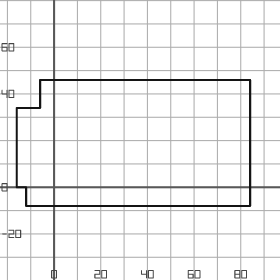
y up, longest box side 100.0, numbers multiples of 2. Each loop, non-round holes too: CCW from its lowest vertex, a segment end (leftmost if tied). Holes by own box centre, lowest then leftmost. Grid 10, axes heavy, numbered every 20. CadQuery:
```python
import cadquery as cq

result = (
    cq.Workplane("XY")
    .moveTo(-12.0, -8.0)
    .lineTo(84.0, -8.0)
    .lineTo(84.0, 46.0)
    .lineTo(-6.0, 46.0)
    .lineTo(-6.0, 34.0)
    .lineTo(-16.0, 34.0)
    .lineTo(-16.0, 0.0)
    .lineTo(-12.0, 0.0)
    .close()
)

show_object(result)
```